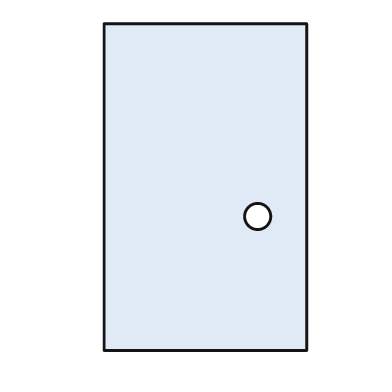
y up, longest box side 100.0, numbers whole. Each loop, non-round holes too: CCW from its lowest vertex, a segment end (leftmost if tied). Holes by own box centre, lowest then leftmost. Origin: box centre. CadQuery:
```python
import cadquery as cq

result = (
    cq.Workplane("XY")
    .moveTo(-31.0, -50.0)
    .lineTo(31.0, -50.0)
    .lineTo(31.0, 50.0)
    .lineTo(-31.0, 50.0)
    .close()
    .moveTo(16.0, -9.0)
    .circle(4.0)
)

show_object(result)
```